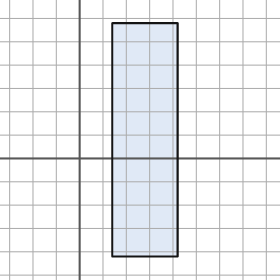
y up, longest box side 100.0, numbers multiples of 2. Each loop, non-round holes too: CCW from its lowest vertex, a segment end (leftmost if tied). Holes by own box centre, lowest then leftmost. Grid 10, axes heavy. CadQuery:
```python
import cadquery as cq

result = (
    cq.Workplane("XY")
    .moveTo(14.0, -42.0)
    .lineTo(42.0, -42.0)
    .lineTo(42.0, 58.0)
    .lineTo(14.0, 58.0)
    .close()
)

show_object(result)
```